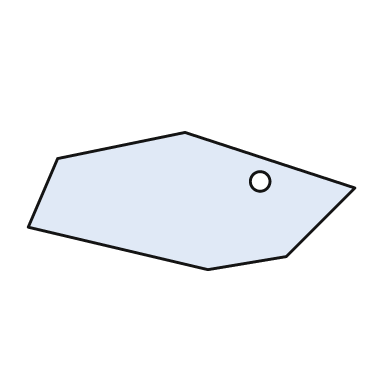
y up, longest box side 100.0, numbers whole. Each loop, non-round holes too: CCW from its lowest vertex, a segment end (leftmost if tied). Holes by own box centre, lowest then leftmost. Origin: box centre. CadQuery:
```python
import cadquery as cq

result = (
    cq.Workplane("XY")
    .moveTo(5.0, -21.0)
    .lineTo(29.0, -17.0)
    .lineTo(50.0, 4.0)
    .lineTo(-2.0, 21.0)
    .lineTo(-41.0, 13.0)
    .lineTo(-50.0, -8.0)
    .close()
    .moveTo(21.0, 6.0)
    .circle(3.0)
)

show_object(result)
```